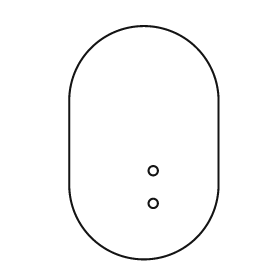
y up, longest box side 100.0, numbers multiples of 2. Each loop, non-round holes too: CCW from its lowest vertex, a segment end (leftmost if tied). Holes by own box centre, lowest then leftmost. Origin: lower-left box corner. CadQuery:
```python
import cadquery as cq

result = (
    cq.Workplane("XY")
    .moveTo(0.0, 32.0)
    .threePointArc((32.0, 0.0), (64.0, 32.0))
    .lineTo(64.0, 68.0)
    .threePointArc((32.0, 100.0), (0.0, 68.0))
    .close()
    .moveTo(36.0, 24.0)
    .circle(2.0)
    .moveTo(36.0, 38.0)
    .circle(2.0)
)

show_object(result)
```